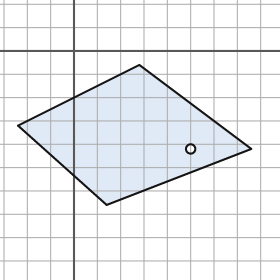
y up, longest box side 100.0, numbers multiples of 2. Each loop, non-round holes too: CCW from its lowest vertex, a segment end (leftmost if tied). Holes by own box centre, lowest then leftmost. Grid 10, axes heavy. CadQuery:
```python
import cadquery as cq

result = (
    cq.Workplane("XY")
    .moveTo(14.0, -66.0)
    .lineTo(76.0, -42.0)
    .lineTo(28.0, -6.0)
    .lineTo(-24.0, -32.0)
    .close()
    .moveTo(50.0, -42.0)
    .circle(2.0)
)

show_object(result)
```